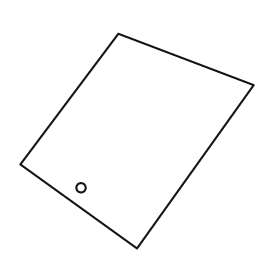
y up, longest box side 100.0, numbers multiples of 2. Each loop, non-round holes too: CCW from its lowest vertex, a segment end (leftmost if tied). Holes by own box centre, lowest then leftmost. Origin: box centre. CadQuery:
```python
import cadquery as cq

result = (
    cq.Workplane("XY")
    .moveTo(0.0, -46.0)
    .lineTo(50.0, 24.0)
    .lineTo(-8.0, 46.0)
    .lineTo(-50.0, -10.0)
    .close()
    .moveTo(-24.0, -20.0)
    .circle(2.0)
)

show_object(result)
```